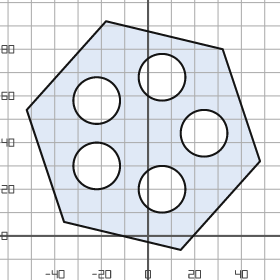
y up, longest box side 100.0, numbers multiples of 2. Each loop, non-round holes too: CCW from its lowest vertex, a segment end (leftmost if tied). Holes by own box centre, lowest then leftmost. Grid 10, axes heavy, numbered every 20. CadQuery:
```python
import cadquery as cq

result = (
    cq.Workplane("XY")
    .moveTo(14.0, -6.0)
    .lineTo(48.0, 32.0)
    .lineTo(32.0, 80.0)
    .lineTo(-18.0, 92.0)
    .lineTo(-52.0, 54.0)
    .lineTo(-36.0, 6.0)
    .close()
    .moveTo(6.0, 20.0)
    .circle(10.0)
    .moveTo(-22.0, 30.0)
    .circle(10.0)
    .moveTo(24.0, 44.0)
    .circle(10.0)
    .moveTo(-22.0, 58.0)
    .circle(10.0)
    .moveTo(6.0, 68.0)
    .circle(10.0)
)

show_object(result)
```